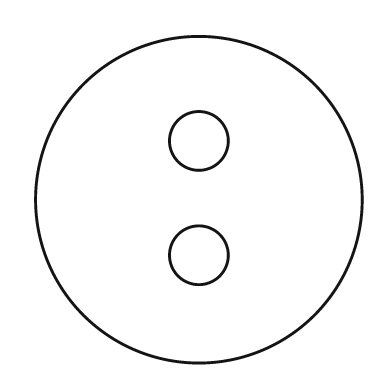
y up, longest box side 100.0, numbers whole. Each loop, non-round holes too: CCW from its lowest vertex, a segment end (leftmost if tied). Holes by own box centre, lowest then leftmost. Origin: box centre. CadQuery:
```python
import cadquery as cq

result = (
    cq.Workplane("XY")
    .moveTo(0.0, 0.0)
    .circle(50.0)
    .moveTo(0.0, -17.0)
    .circle(9.0)
    .moveTo(0.0, 18.0)
    .circle(9.0)
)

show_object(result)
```